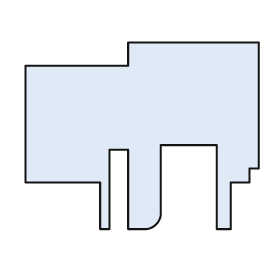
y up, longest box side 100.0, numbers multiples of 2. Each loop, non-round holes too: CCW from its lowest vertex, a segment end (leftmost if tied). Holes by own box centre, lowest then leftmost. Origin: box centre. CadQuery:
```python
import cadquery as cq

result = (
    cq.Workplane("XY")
    .moveTo(-18.0, -40.0)
    .lineTo(-14.0, -40.0)
    .lineTo(-14.0, -6.0)
    .lineTo(-6.0, -6.0)
    .lineTo(-6.0, -40.0)
    .lineTo(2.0, -40.0)
    .threePointArc((6.0, -38.0), (8.0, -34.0))
    .lineTo(8.0, -4.0)
    .lineTo(32.0, -4.0)
    .lineTo(32.0, -40.0)
    .lineTo(38.0, -40.0)
    .lineTo(38.0, -20.0)
    .lineTo(46.0, -20.0)
    .lineTo(46.0, -14.0)
    .lineTo(50.0, -14.0)
    .lineTo(50.0, 40.0)
    .lineTo(-6.0, 40.0)
    .lineTo(-6.0, 30.0)
    .lineTo(-50.0, 30.0)
    .lineTo(-50.0, -20.0)
    .lineTo(-18.0, -20.0)
    .close()
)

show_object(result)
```